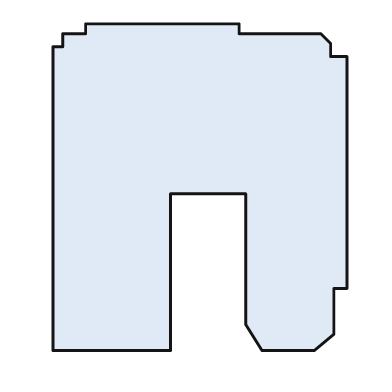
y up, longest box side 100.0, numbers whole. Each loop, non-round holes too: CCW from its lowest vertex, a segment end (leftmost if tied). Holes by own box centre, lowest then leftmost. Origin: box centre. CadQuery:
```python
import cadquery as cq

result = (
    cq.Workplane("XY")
    .moveTo(-45.0, -50.0)
    .lineTo(-9.0, -50.0)
    .lineTo(-9.0, -2.0)
    .lineTo(14.0, -2.0)
    .lineTo(14.0, -42.0)
    .lineTo(19.0, -50.0)
    .lineTo(35.0, -50.0)
    .lineTo(41.0, -45.0)
    .lineTo(41.0, -31.0)
    .lineTo(45.0, -31.0)
    .lineTo(45.0, 40.0)
    .lineTo(40.0, 40.0)
    .lineTo(40.0, 44.0)
    .lineTo(37.0, 47.0)
    .lineTo(12.0, 47.0)
    .lineTo(12.0, 50.0)
    .lineTo(-35.0, 50.0)
    .lineTo(-35.0, 47.0)
    .lineTo(-42.0, 47.0)
    .lineTo(-42.0, 43.0)
    .lineTo(-45.0, 43.0)
    .close()
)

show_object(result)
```